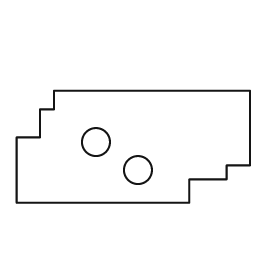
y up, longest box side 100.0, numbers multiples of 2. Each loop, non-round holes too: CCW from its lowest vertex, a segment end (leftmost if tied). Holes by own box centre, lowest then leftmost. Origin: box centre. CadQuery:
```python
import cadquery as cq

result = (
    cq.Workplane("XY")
    .moveTo(-50.0, -24.0)
    .lineTo(24.0, -24.0)
    .lineTo(24.0, -14.0)
    .lineTo(40.0, -14.0)
    .lineTo(40.0, -8.0)
    .lineTo(50.0, -8.0)
    .lineTo(50.0, 24.0)
    .lineTo(-34.0, 24.0)
    .lineTo(-34.0, 16.0)
    .lineTo(-40.0, 16.0)
    .lineTo(-40.0, 4.0)
    .lineTo(-50.0, 4.0)
    .close()
    .moveTo(2.0, -10.0)
    .circle(6.0)
    .moveTo(-16.0, 2.0)
    .circle(6.0)
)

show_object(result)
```